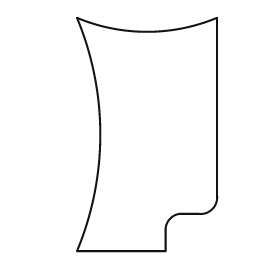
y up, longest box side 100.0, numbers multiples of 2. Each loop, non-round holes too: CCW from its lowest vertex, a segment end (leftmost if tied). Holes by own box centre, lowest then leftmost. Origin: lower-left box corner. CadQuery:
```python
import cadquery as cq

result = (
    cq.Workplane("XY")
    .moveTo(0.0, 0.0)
    .lineTo(38.0, 0.0)
    .lineTo(38.0, 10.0)
    .threePointArc((40.0, 14.0), (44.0, 16.0))
    .lineTo(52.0, 16.0)
    .threePointArc((58.0, 18.0), (60.0, 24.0))
    .lineTo(60.0, 100.0)
    .threePointArc((30.0, 94.0), (0.0, 100.0))
    .threePointArc((10.0, 50.0), (0.0, 0.0))
    .close()
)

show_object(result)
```